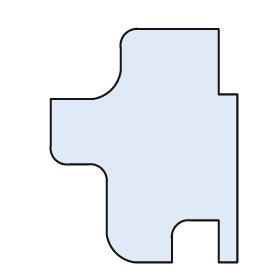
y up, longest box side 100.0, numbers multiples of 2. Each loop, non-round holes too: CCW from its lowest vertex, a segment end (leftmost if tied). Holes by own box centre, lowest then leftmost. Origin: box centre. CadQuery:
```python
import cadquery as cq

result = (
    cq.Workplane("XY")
    .moveTo(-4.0, -50.0)
    .lineTo(12.0, -50.0)
    .lineTo(12.0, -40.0)
    .threePointArc((14.0, -34.0), (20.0, -32.0))
    .lineTo(32.0, -32.0)
    .lineTo(32.0, -50.0)
    .lineTo(40.0, -50.0)
    .lineTo(40.0, 22.0)
    .lineTo(32.0, 22.0)
    .lineTo(32.0, 50.0)
    .lineTo(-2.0, 50.0)
    .threePointArc((-8.0, 48.0), (-10.0, 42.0))
    .lineTo(-10.0, 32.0)
    .threePointArc((-14.0, 24.0), (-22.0, 20.0))
    .lineTo(-40.0, 20.0)
    .lineTo(-40.0, 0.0)
    .threePointArc((-38.0, -6.0), (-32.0, -8.0))
    .lineTo(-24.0, -8.0)
    .threePointArc((-18.0, -10.0), (-16.0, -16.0))
    .lineTo(-16.0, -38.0)
    .threePointArc((-12.0, -46.0), (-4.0, -50.0))
    .close()
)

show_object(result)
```